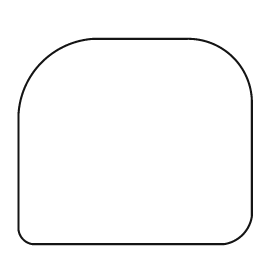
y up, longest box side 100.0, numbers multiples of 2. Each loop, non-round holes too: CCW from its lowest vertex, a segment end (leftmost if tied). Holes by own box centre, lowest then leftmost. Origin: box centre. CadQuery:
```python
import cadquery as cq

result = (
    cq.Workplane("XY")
    .moveTo(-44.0, -44.0)
    .lineTo(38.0, -44.0)
    .threePointArc((46.0, -40.0), (50.0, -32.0))
    .lineTo(50.0, 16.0)
    .threePointArc((42.0, 36.0), (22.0, 44.0))
    .lineTo(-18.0, 44.0)
    .threePointArc((-40.0, 34.0), (-50.0, 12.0))
    .lineTo(-50.0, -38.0)
    .threePointArc((-48.0, -42.0), (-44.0, -44.0))
    .close()
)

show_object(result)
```